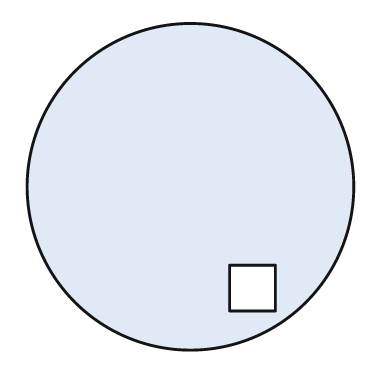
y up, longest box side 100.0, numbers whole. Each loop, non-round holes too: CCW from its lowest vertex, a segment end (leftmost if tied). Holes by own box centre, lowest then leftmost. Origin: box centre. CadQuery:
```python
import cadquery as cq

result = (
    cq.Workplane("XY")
    .moveTo(0.0, 0.0)
    .circle(50.0)
    .moveTo(12.0, -38.0)
    .lineTo(26.0, -38.0)
    .lineTo(26.0, -24.0)
    .lineTo(12.0, -24.0)
    .close()
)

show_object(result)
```